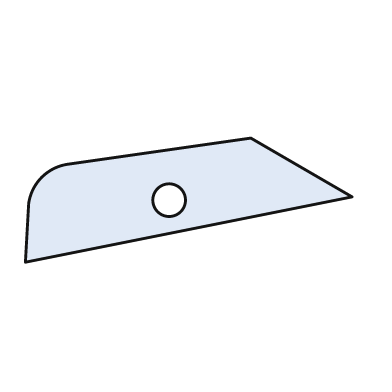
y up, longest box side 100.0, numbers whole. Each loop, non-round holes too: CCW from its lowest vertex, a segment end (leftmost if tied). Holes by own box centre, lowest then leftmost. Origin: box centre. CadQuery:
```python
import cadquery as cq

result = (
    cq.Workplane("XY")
    .moveTo(-50.0, -19.0)
    .lineTo(50.0, 1.0)
    .lineTo(19.0, 19.0)
    .lineTo(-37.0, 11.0)
    .threePointArc((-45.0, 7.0), (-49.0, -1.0))
    .close()
    .moveTo(-6.0, 0.0)
    .circle(5.0)
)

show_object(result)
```